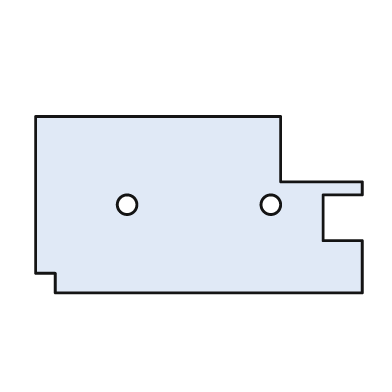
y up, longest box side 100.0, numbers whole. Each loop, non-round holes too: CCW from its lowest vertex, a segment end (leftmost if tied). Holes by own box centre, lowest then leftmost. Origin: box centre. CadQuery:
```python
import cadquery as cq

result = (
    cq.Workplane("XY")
    .moveTo(-44.0, -27.0)
    .lineTo(50.0, -27.0)
    .lineTo(50.0, -11.0)
    .lineTo(38.0, -11.0)
    .lineTo(38.0, 3.0)
    .lineTo(50.0, 3.0)
    .lineTo(50.0, 7.0)
    .lineTo(25.0, 7.0)
    .lineTo(25.0, 27.0)
    .lineTo(-50.0, 27.0)
    .lineTo(-50.0, -21.0)
    .lineTo(-44.0, -21.0)
    .close()
    .moveTo(-22.0, 0.0)
    .circle(3.0)
    .moveTo(22.0, 0.0)
    .circle(3.0)
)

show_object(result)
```